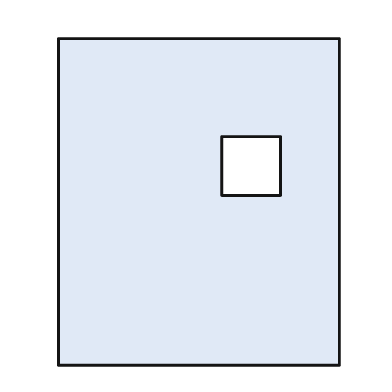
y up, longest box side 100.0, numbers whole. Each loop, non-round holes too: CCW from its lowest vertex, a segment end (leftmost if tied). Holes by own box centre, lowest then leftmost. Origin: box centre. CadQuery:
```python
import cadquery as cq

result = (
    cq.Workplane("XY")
    .moveTo(-43.0, -50.0)
    .lineTo(43.0, -50.0)
    .lineTo(43.0, 50.0)
    .lineTo(-43.0, 50.0)
    .close()
    .moveTo(7.0, 2.0)
    .lineTo(25.0, 2.0)
    .lineTo(25.0, 20.0)
    .lineTo(7.0, 20.0)
    .close()
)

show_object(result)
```